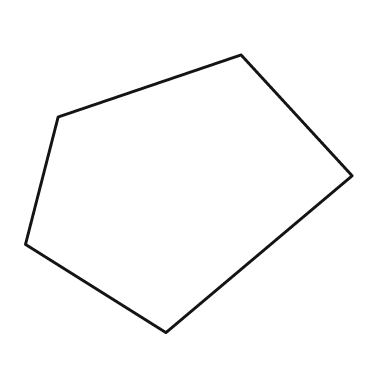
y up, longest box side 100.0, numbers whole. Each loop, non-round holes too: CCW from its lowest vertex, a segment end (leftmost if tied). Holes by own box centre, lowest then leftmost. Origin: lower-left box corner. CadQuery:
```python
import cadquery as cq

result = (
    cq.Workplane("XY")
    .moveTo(43.0, 0.0)
    .lineTo(100.0, 48.0)
    .lineTo(66.0, 85.0)
    .lineTo(10.0, 66.0)
    .lineTo(0.0, 27.0)
    .close()
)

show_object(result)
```